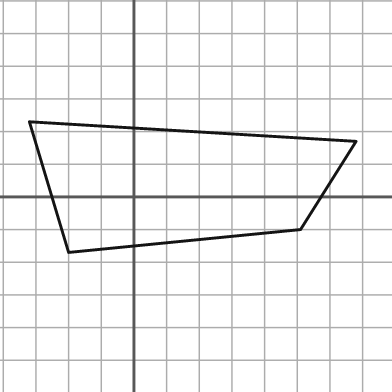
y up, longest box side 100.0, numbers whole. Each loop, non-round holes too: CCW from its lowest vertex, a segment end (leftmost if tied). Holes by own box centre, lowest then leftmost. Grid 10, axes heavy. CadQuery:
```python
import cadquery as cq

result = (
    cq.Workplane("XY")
    .moveTo(-20.0, -17.0)
    .lineTo(51.0, -10.0)
    .lineTo(68.0, 17.0)
    .lineTo(-32.0, 23.0)
    .close()
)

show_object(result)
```